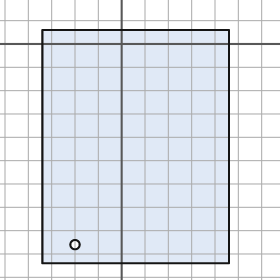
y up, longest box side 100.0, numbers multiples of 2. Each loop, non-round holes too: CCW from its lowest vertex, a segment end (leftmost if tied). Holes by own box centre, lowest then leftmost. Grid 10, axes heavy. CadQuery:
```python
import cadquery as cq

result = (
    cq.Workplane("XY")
    .moveTo(-34.0, -94.0)
    .lineTo(46.0, -94.0)
    .lineTo(46.0, 6.0)
    .lineTo(-34.0, 6.0)
    .close()
    .moveTo(-20.0, -86.0)
    .circle(2.0)
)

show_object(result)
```